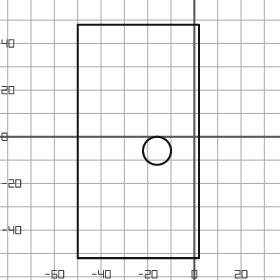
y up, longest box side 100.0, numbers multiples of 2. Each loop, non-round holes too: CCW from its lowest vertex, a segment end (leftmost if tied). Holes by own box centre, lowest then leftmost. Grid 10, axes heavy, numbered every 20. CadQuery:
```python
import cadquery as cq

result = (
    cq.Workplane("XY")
    .moveTo(-50.0, -52.0)
    .lineTo(2.0, -52.0)
    .lineTo(2.0, 48.0)
    .lineTo(-50.0, 48.0)
    .close()
    .moveTo(-16.0, -6.0)
    .circle(6.0)
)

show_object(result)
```